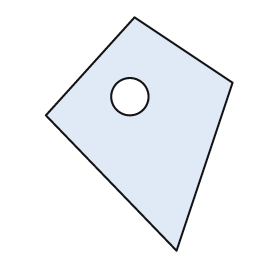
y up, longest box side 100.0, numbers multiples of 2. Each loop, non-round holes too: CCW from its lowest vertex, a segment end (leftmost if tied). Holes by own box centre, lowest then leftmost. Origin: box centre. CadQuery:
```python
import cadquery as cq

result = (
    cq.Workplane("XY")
    .moveTo(16.0, -50.0)
    .lineTo(40.0, 22.0)
    .lineTo(-2.0, 50.0)
    .lineTo(-40.0, 8.0)
    .close()
    .moveTo(-4.0, 16.0)
    .circle(8.0)
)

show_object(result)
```